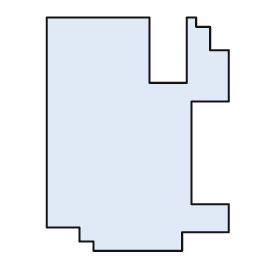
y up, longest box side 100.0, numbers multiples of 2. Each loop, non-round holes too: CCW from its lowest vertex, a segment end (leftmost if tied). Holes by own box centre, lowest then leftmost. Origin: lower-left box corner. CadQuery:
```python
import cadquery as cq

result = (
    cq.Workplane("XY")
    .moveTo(20.0, 0.0)
    .lineTo(58.0, 0.0)
    .lineTo(58.0, 8.0)
    .lineTo(78.0, 8.0)
    .lineTo(78.0, 20.0)
    .lineTo(62.0, 20.0)
    .lineTo(62.0, 64.0)
    .lineTo(78.0, 64.0)
    .lineTo(78.0, 86.0)
    .lineTo(70.0, 86.0)
    .lineTo(70.0, 96.0)
    .lineTo(64.0, 96.0)
    .lineTo(64.0, 100.0)
    .lineTo(60.0, 100.0)
    .lineTo(60.0, 72.0)
    .lineTo(44.0, 72.0)
    .lineTo(44.0, 100.0)
    .lineTo(0.0, 100.0)
    .lineTo(0.0, 10.0)
    .lineTo(14.0, 10.0)
    .lineTo(14.0, 4.0)
    .lineTo(20.0, 4.0)
    .close()
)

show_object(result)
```